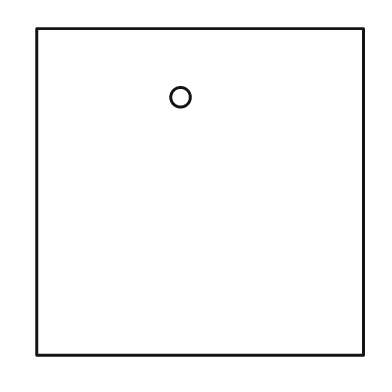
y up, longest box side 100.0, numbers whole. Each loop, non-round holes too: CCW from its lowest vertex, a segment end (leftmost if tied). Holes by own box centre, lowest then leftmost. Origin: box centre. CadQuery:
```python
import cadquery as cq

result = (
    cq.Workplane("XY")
    .moveTo(-50.0, -50.0)
    .lineTo(50.0, -50.0)
    .lineTo(50.0, 50.0)
    .lineTo(-50.0, 50.0)
    .close()
    .moveTo(-6.0, 29.0)
    .circle(3.0)
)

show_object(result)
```